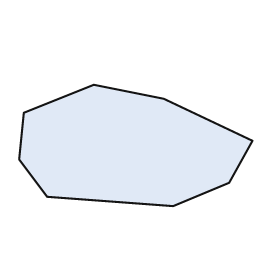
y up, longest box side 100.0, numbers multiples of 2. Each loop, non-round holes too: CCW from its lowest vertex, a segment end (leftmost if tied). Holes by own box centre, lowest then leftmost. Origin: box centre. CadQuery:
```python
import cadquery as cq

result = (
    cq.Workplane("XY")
    .moveTo(16.0, -26.0)
    .lineTo(40.0, -16.0)
    .lineTo(50.0, 2.0)
    .lineTo(12.0, 20.0)
    .lineTo(-18.0, 26.0)
    .lineTo(-48.0, 14.0)
    .lineTo(-50.0, -6.0)
    .lineTo(-38.0, -22.0)
    .close()
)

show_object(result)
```